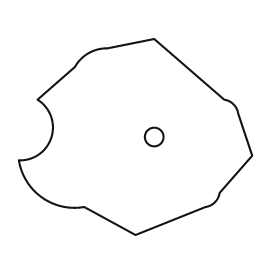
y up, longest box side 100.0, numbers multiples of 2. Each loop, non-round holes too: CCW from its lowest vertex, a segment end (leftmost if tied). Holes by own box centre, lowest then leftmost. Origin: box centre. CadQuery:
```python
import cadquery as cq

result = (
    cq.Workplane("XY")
    .moveTo(0.0, -42.0)
    .lineTo(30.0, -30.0)
    .threePointArc((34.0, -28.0), (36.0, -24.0))
    .lineTo(50.0, -8.0)
    .lineTo(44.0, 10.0)
    .threePointArc((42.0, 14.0), (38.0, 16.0))
    .lineTo(8.0, 42.0)
    .lineTo(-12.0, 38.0)
    .threePointArc((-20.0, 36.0), (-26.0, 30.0))
    .lineTo(-42.0, 16.0)
    .threePointArc((-36.0, 0.0), (-50.0, -10.0))
    .threePointArc((-40.0, -26.0), (-22.0, -30.0))
    .close()
    .moveTo(8.0, 0.0)
    .circle(4.0)
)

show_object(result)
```